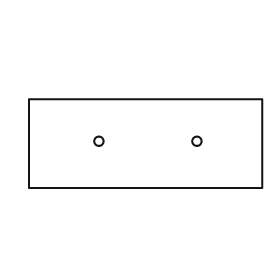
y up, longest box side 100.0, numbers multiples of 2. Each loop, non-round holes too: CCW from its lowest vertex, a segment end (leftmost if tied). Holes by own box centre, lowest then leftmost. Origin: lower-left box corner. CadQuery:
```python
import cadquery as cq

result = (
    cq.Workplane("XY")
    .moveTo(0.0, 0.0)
    .lineTo(100.0, 0.0)
    .lineTo(100.0, 38.0)
    .lineTo(0.0, 38.0)
    .close()
    .moveTo(30.0, 20.0)
    .circle(2.0)
    .moveTo(72.0, 20.0)
    .circle(2.0)
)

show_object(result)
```